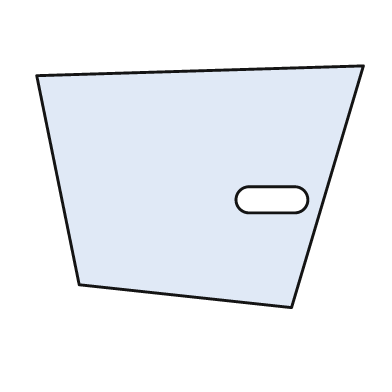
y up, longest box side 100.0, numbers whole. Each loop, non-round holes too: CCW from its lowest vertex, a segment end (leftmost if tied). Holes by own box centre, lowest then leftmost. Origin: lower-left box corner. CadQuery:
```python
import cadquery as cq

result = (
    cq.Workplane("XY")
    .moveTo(78.0, 0.0)
    .lineTo(100.0, 74.0)
    .lineTo(0.0, 71.0)
    .lineTo(13.0, 7.0)
    .close()
    .moveTo(65.0, 29.0)
    .lineTo(79.0, 29.0)
    .threePointArc((83.0, 33.0), (79.0, 37.0))
    .lineTo(65.0, 37.0)
    .threePointArc((61.0, 33.0), (65.0, 29.0))
    .close()
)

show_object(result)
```